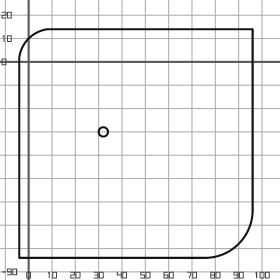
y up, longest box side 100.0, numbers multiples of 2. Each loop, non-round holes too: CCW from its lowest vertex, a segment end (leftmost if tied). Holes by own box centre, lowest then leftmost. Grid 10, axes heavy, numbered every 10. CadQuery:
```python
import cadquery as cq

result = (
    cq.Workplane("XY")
    .moveTo(-4.0, -84.0)
    .lineTo(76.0, -84.0)
    .threePointArc((90.0, -78.0), (96.0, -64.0))
    .lineTo(96.0, 14.0)
    .lineTo(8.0, 14.0)
    .threePointArc((0.0, 10.0), (-4.0, 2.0))
    .close()
    .moveTo(32.0, -30.0)
    .circle(2.0)
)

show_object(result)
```